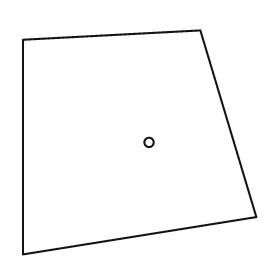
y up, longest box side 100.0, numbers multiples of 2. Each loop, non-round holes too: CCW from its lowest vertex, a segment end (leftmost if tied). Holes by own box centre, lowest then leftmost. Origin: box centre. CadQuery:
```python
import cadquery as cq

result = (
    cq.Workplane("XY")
    .moveTo(-50.0, -48.0)
    .lineTo(50.0, -32.0)
    .lineTo(26.0, 48.0)
    .lineTo(-50.0, 44.0)
    .close()
    .moveTo(4.0, 0.0)
    .circle(2.0)
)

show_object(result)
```